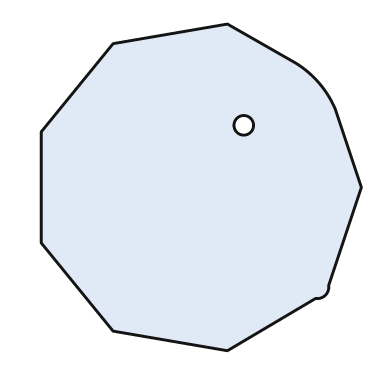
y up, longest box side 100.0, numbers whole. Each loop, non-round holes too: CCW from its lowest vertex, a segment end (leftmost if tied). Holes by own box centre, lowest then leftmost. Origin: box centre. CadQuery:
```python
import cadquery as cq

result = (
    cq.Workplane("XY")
    .moveTo(8.0, -50.0)
    .lineTo(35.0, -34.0)
    .threePointArc((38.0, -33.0), (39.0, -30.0))
    .lineTo(49.0, 0.0)
    .lineTo(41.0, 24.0)
    .threePointArc((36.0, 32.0), (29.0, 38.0))
    .lineTo(8.0, 50.0)
    .lineTo(-27.0, 44.0)
    .lineTo(-49.0, 17.0)
    .lineTo(-49.0, -17.0)
    .lineTo(-27.0, -44.0)
    .close()
    .moveTo(13.0, 19.0)
    .circle(3.0)
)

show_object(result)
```